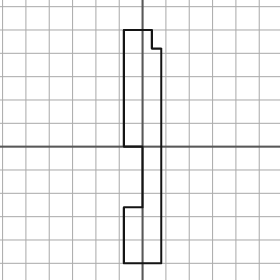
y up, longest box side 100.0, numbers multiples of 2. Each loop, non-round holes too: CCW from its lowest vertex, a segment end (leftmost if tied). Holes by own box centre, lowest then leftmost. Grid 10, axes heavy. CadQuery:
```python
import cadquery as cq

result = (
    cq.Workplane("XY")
    .moveTo(-8.0, -50.0)
    .lineTo(8.0, -50.0)
    .lineTo(8.0, 42.0)
    .lineTo(4.0, 42.0)
    .lineTo(4.0, 50.0)
    .lineTo(-8.0, 50.0)
    .lineTo(-8.0, 0.0)
    .lineTo(0.0, 0.0)
    .lineTo(0.0, -26.0)
    .lineTo(-8.0, -26.0)
    .close()
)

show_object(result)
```